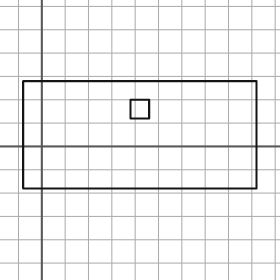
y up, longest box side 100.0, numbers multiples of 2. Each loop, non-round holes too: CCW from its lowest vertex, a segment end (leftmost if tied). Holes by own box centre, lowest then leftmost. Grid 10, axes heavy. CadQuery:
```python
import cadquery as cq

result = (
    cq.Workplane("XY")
    .moveTo(-8.0, -18.0)
    .lineTo(92.0, -18.0)
    .lineTo(92.0, 28.0)
    .lineTo(-8.0, 28.0)
    .close()
    .moveTo(38.0, 12.0)
    .lineTo(46.0, 12.0)
    .lineTo(46.0, 20.0)
    .lineTo(38.0, 20.0)
    .close()
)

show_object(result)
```